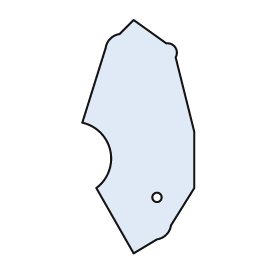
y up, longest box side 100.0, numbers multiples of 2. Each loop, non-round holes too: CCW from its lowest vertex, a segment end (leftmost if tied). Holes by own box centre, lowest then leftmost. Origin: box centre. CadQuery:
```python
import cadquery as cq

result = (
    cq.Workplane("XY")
    .moveTo(-2.0, -50.0)
    .lineTo(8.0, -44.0)
    .threePointArc((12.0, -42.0), (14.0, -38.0))
    .lineTo(24.0, -22.0)
    .lineTo(24.0, 2.0)
    .lineTo(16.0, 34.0)
    .threePointArc((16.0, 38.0), (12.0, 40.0))
    .lineTo(-2.0, 50.0)
    .lineTo(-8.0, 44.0)
    .threePointArc((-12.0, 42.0), (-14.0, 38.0))
    .lineTo(-24.0, 6.0)
    .threePointArc((-12.0, -6.0), (-18.0, -22.0))
    .close()
    .moveTo(8.0, -26.0)
    .circle(2.0)
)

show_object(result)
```